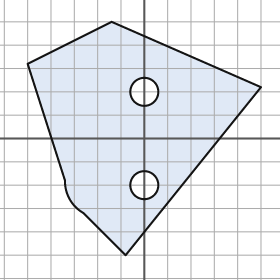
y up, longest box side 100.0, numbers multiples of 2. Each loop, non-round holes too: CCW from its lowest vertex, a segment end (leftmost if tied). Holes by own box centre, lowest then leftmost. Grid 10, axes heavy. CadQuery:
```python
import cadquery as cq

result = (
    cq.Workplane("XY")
    .moveTo(-8.0, -50.0)
    .lineTo(50.0, 22.0)
    .lineTo(-14.0, 50.0)
    .lineTo(-50.0, 32.0)
    .lineTo(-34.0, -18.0)
    .threePointArc((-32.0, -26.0), (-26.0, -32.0))
    .close()
    .moveTo(0.0, -20.0)
    .circle(6.0)
    .moveTo(0.0, 20.0)
    .circle(6.0)
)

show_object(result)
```